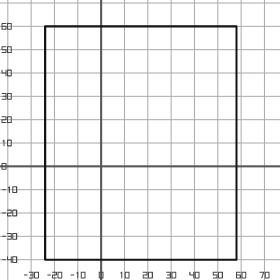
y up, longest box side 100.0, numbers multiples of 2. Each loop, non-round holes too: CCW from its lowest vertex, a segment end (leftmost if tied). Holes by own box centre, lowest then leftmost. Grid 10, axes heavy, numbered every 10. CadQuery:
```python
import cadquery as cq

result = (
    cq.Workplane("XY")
    .moveTo(-24.0, -40.0)
    .lineTo(58.0, -40.0)
    .lineTo(58.0, 60.0)
    .lineTo(-24.0, 60.0)
    .close()
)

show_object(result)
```